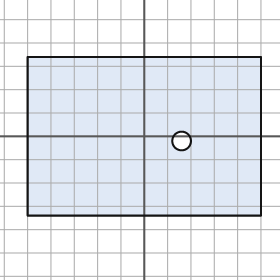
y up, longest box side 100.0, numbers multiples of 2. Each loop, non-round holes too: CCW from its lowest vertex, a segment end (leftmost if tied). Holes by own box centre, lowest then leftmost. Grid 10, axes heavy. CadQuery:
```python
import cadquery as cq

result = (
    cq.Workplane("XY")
    .moveTo(-50.0, -34.0)
    .lineTo(50.0, -34.0)
    .lineTo(50.0, 34.0)
    .lineTo(-50.0, 34.0)
    .close()
    .moveTo(16.0, -2.0)
    .circle(4.0)
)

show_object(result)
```